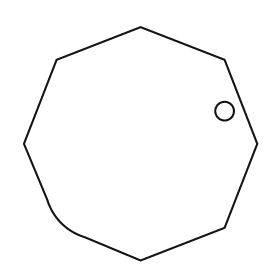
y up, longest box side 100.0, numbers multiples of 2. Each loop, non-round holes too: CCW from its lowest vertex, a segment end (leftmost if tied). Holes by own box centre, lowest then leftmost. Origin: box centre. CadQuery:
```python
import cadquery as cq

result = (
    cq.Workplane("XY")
    .moveTo(0.0, -50.0)
    .lineTo(36.0, -36.0)
    .lineTo(50.0, 0.0)
    .lineTo(36.0, 36.0)
    .lineTo(0.0, 50.0)
    .lineTo(-36.0, 36.0)
    .lineTo(-50.0, 0.0)
    .lineTo(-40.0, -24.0)
    .threePointArc((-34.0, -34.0), (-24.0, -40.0))
    .close()
    .moveTo(36.0, 14.0)
    .circle(4.0)
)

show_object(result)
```